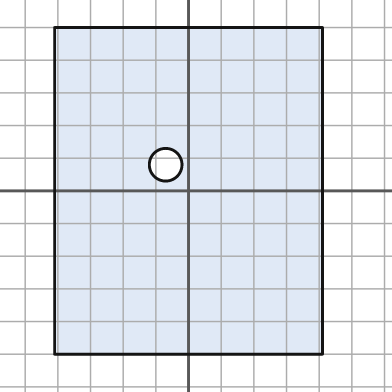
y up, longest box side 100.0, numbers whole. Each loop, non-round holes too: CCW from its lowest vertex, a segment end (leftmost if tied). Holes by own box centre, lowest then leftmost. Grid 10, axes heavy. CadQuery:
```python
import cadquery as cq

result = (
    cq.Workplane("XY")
    .moveTo(-41.0, -50.0)
    .lineTo(41.0, -50.0)
    .lineTo(41.0, 50.0)
    .lineTo(-41.0, 50.0)
    .close()
    .moveTo(-7.0, 8.0)
    .circle(5.0)
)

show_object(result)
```